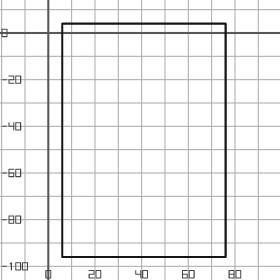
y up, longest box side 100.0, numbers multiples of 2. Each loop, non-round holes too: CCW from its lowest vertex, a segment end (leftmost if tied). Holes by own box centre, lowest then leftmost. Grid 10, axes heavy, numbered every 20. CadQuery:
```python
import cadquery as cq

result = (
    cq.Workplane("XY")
    .moveTo(6.0, -96.0)
    .lineTo(76.0, -96.0)
    .lineTo(76.0, 4.0)
    .lineTo(6.0, 4.0)
    .close()
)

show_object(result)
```